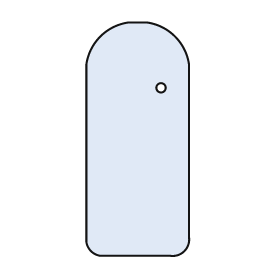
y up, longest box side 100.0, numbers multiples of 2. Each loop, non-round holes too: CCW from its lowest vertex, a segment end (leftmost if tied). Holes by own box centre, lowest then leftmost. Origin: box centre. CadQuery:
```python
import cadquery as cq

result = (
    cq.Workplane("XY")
    .moveTo(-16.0, -50.0)
    .lineTo(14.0, -50.0)
    .threePointArc((20.0, -48.0), (22.0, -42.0))
    .lineTo(22.0, 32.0)
    .threePointArc((16.0, 44.0), (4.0, 50.0))
    .lineTo(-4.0, 50.0)
    .threePointArc((-16.0, 44.0), (-22.0, 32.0))
    .lineTo(-22.0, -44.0)
    .threePointArc((-20.0, -48.0), (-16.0, -50.0))
    .close()
    .moveTo(10.0, 22.0)
    .circle(2.0)
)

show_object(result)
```